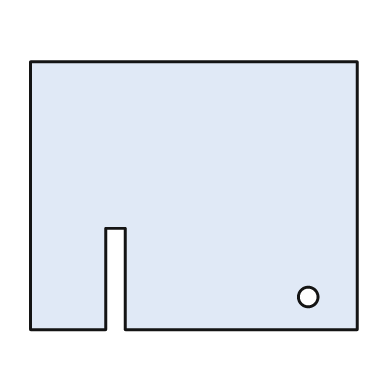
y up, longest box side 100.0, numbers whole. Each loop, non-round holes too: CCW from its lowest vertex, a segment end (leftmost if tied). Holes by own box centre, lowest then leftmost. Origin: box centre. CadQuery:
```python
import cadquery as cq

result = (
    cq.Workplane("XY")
    .moveTo(-50.0, -41.0)
    .lineTo(-27.0, -41.0)
    .lineTo(-27.0, -10.0)
    .lineTo(-21.0, -10.0)
    .lineTo(-21.0, -41.0)
    .lineTo(50.0, -41.0)
    .lineTo(50.0, 41.0)
    .lineTo(-50.0, 41.0)
    .close()
    .moveTo(35.0, -31.0)
    .circle(3.0)
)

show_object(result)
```